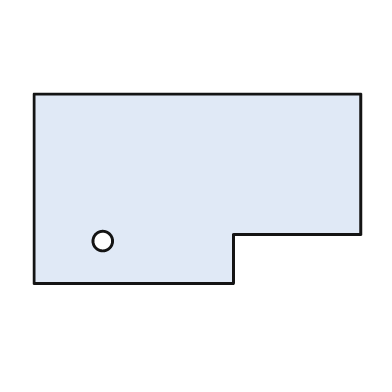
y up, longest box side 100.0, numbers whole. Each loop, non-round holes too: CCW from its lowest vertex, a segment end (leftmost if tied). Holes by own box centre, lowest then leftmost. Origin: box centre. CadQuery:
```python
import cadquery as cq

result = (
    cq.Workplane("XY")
    .moveTo(-50.0, -29.0)
    .lineTo(11.0, -29.0)
    .lineTo(11.0, -14.0)
    .lineTo(50.0, -14.0)
    .lineTo(50.0, 29.0)
    .lineTo(-50.0, 29.0)
    .close()
    .moveTo(-29.0, -16.0)
    .circle(3.0)
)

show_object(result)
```